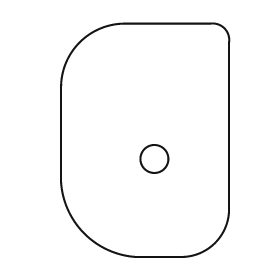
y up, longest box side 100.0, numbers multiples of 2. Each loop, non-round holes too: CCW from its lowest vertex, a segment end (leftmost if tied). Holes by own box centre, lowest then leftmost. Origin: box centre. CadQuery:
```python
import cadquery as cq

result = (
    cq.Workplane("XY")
    .moveTo(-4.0, -50.0)
    .lineTo(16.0, -50.0)
    .threePointArc((30.0, -44.0), (36.0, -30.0))
    .lineTo(36.0, 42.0)
    .threePointArc((34.0, 48.0), (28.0, 50.0))
    .lineTo(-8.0, 50.0)
    .threePointArc((-28.0, 42.0), (-36.0, 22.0))
    .lineTo(-36.0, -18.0)
    .threePointArc((-26.0, -40.0), (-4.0, -50.0))
    .close()
    .moveTo(4.0, -8.0)
    .circle(6.0)
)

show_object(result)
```